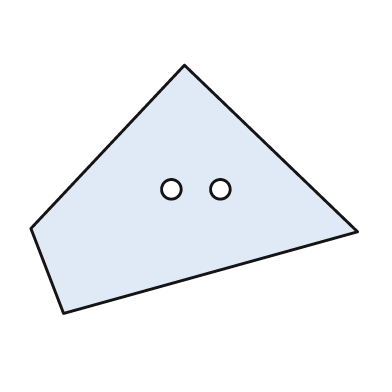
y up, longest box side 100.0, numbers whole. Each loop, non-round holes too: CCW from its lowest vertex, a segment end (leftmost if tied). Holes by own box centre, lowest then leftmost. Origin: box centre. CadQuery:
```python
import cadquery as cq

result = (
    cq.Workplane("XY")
    .moveTo(-40.0, -38.0)
    .lineTo(50.0, -13.0)
    .lineTo(-3.0, 38.0)
    .lineTo(-50.0, -12.0)
    .close()
    .moveTo(-7.0, 0.0)
    .circle(3.0)
    .moveTo(8.0, 0.0)
    .circle(3.0)
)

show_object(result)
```